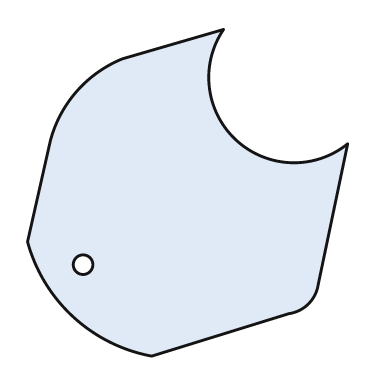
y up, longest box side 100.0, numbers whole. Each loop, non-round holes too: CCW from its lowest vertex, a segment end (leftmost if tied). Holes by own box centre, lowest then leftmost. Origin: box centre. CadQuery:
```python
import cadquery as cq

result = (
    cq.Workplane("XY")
    .moveTo(-11.0, -50.0)
    .lineTo(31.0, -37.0)
    .threePointArc((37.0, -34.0), (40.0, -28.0))
    .lineTo(49.0, 15.0)
    .threePointArc((15.0, 16.0), (11.0, 50.0))
    .lineTo(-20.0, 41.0)
    .threePointArc((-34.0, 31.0), (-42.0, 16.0))
    .lineTo(-49.0, -15.0)
    .threePointArc((-35.0, -38.0), (-11.0, -50.0))
    .close()
    .moveTo(-32.0, -22.0)
    .circle(3.0)
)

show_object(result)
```